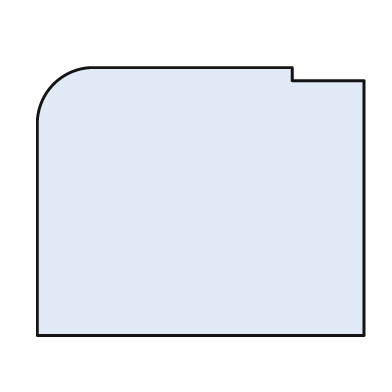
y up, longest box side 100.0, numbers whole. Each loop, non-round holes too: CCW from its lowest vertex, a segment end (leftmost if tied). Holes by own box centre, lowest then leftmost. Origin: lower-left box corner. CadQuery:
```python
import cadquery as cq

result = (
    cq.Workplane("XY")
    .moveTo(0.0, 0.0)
    .lineTo(100.0, 0.0)
    .lineTo(100.0, 78.0)
    .lineTo(78.0, 78.0)
    .lineTo(78.0, 82.0)
    .lineTo(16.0, 82.0)
    .threePointArc((5.0, 77.0), (0.0, 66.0))
    .close()
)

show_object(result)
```